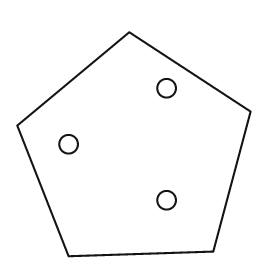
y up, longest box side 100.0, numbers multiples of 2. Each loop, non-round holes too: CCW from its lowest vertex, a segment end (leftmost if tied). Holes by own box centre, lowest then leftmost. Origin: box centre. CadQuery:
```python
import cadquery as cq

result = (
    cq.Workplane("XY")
    .moveTo(-28.0, -48.0)
    .lineTo(34.0, -46.0)
    .lineTo(50.0, 14.0)
    .lineTo(-2.0, 48.0)
    .lineTo(-50.0, 8.0)
    .close()
    .moveTo(14.0, -24.0)
    .circle(4.0)
    .moveTo(-28.0, 0.0)
    .circle(4.0)
    .moveTo(14.0, 24.0)
    .circle(4.0)
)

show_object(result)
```